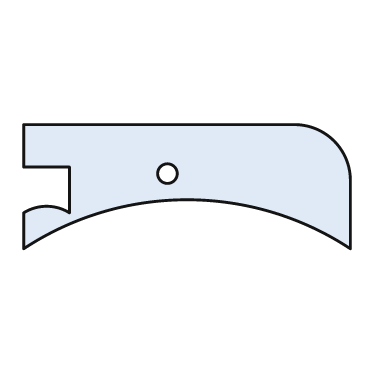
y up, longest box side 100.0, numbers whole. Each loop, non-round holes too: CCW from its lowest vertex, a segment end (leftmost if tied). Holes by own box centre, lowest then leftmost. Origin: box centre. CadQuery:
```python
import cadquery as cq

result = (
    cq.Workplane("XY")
    .moveTo(-50.0, -19.0)
    .threePointArc((0.0, -4.0), (50.0, -19.0))
    .lineTo(50.0, 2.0)
    .threePointArc((45.0, 14.0), (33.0, 19.0))
    .lineTo(-50.0, 19.0)
    .lineTo(-50.0, 6.0)
    .lineTo(-36.0, 6.0)
    .lineTo(-36.0, -8.0)
    .threePointArc((-43.0, -6.0), (-50.0, -8.0))
    .close()
    .moveTo(-6.0, 4.0)
    .circle(3.0)
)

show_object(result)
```